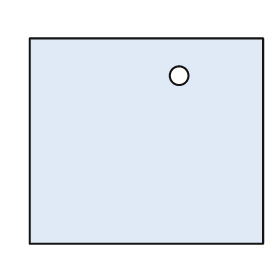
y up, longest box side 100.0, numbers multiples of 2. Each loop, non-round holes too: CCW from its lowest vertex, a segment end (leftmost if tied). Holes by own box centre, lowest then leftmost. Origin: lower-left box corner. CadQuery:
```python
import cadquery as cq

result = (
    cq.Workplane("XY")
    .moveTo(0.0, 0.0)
    .lineTo(100.0, 0.0)
    .lineTo(100.0, 88.0)
    .lineTo(0.0, 88.0)
    .close()
    .moveTo(64.0, 72.0)
    .circle(4.0)
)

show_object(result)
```